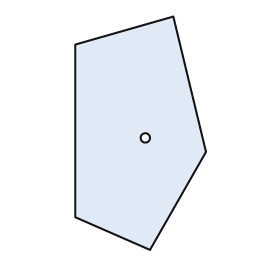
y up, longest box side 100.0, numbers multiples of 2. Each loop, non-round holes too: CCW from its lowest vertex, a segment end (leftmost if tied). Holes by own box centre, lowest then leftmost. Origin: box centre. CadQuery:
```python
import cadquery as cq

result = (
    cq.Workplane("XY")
    .moveTo(4.0, -50.0)
    .lineTo(28.0, -8.0)
    .lineTo(14.0, 50.0)
    .lineTo(-28.0, 38.0)
    .lineTo(-28.0, -36.0)
    .close()
    .moveTo(2.0, -2.0)
    .circle(2.0)
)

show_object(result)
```